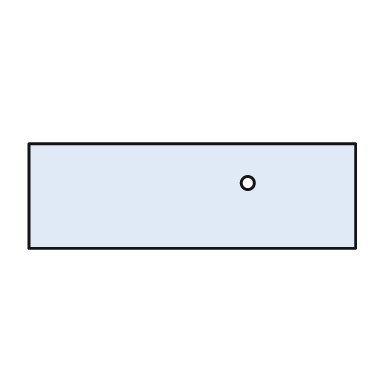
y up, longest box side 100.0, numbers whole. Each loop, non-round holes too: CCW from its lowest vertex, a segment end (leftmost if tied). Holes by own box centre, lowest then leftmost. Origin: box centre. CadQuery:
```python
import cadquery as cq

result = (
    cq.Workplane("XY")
    .moveTo(-50.0, -16.0)
    .lineTo(50.0, -16.0)
    .lineTo(50.0, 16.0)
    .lineTo(-50.0, 16.0)
    .close()
    .moveTo(17.0, 4.0)
    .circle(2.0)
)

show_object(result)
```